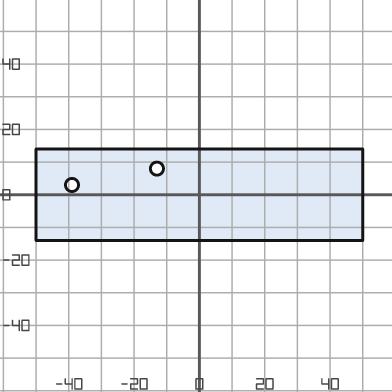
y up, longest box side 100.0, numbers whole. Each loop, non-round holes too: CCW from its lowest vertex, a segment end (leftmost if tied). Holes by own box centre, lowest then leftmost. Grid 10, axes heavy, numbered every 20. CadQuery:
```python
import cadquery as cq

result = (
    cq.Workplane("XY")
    .moveTo(-50.0, -14.0)
    .lineTo(50.0, -14.0)
    .lineTo(50.0, 14.0)
    .lineTo(-50.0, 14.0)
    .close()
    .moveTo(-39.0, 3.0)
    .circle(2.0)
    .moveTo(-13.0, 8.0)
    .circle(2.0)
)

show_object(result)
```